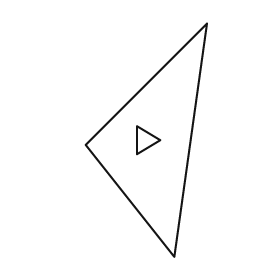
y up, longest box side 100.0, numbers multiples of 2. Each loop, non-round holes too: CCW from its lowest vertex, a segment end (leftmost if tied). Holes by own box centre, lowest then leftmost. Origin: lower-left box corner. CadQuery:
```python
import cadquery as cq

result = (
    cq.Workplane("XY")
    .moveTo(38.0, 0.0)
    .lineTo(52.0, 100.0)
    .lineTo(0.0, 48.0)
    .close()
    .moveTo(22.0, 44.0)
    .lineTo(32.0, 50.0)
    .lineTo(22.0, 56.0)
    .close()
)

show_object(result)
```